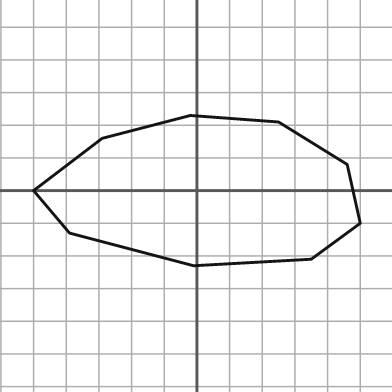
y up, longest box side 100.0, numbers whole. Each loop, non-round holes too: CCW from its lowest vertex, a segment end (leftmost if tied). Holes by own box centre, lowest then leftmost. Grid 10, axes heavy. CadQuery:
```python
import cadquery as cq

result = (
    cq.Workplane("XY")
    .moveTo(-1.0, -23.0)
    .lineTo(35.0, -21.0)
    .lineTo(50.0, -10.0)
    .lineTo(46.0, 8.0)
    .lineTo(25.0, 21.0)
    .lineTo(-2.0, 23.0)
    .lineTo(-29.0, 16.0)
    .lineTo(-50.0, 0.0)
    .lineTo(-39.0, -13.0)
    .close()
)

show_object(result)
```